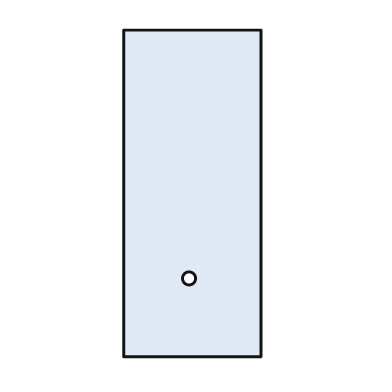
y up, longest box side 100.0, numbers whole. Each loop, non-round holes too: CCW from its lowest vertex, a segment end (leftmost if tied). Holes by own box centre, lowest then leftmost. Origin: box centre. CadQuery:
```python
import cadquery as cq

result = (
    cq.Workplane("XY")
    .moveTo(-21.0, -50.0)
    .lineTo(21.0, -50.0)
    .lineTo(21.0, 50.0)
    .lineTo(-21.0, 50.0)
    .close()
    .moveTo(-1.0, -26.0)
    .circle(2.0)
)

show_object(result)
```